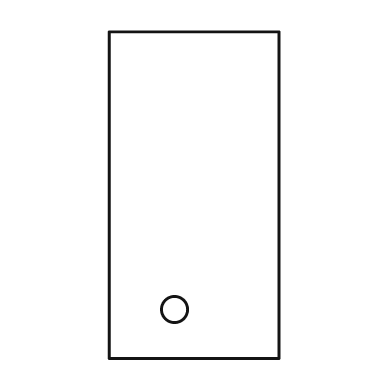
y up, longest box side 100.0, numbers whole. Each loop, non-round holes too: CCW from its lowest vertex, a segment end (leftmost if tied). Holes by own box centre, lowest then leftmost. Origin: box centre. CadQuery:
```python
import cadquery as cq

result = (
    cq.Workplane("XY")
    .moveTo(-26.0, -50.0)
    .lineTo(26.0, -50.0)
    .lineTo(26.0, 50.0)
    .lineTo(-26.0, 50.0)
    .close()
    .moveTo(-6.0, -35.0)
    .circle(4.0)
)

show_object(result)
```